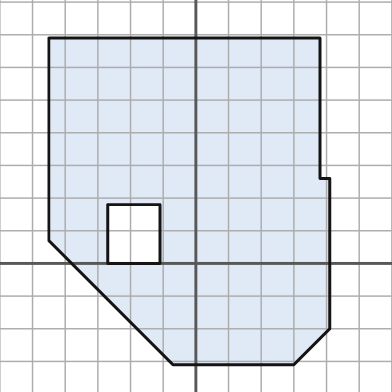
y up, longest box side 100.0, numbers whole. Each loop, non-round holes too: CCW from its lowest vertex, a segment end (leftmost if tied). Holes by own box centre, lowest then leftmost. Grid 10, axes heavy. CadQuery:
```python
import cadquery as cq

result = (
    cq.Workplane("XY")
    .moveTo(-7.0, -31.0)
    .lineTo(30.0, -31.0)
    .lineTo(41.0, -20.0)
    .lineTo(41.0, 26.0)
    .lineTo(38.0, 26.0)
    .lineTo(38.0, 69.0)
    .lineTo(-45.0, 69.0)
    .lineTo(-45.0, 7.0)
    .close()
    .moveTo(-27.0, 0.0)
    .lineTo(-11.0, 0.0)
    .lineTo(-11.0, 18.0)
    .lineTo(-27.0, 18.0)
    .close()
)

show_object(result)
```